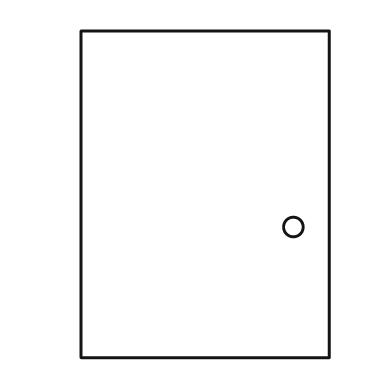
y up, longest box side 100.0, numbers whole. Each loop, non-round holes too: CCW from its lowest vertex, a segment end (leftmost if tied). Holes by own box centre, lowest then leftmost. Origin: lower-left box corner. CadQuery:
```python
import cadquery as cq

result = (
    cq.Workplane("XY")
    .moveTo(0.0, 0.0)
    .lineTo(76.0, 0.0)
    .lineTo(76.0, 100.0)
    .lineTo(0.0, 100.0)
    .close()
    .moveTo(65.0, 40.0)
    .circle(3.0)
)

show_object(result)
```